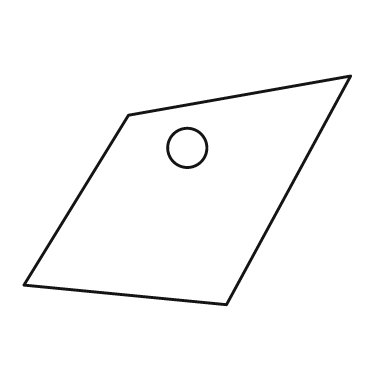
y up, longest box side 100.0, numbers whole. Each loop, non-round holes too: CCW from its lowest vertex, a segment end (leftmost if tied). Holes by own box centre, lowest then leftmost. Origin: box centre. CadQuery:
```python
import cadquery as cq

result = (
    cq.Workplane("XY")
    .moveTo(12.0, -35.0)
    .lineTo(50.0, 35.0)
    .lineTo(-18.0, 23.0)
    .lineTo(-50.0, -29.0)
    .close()
    .moveTo(0.0, 13.0)
    .circle(6.0)
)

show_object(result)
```